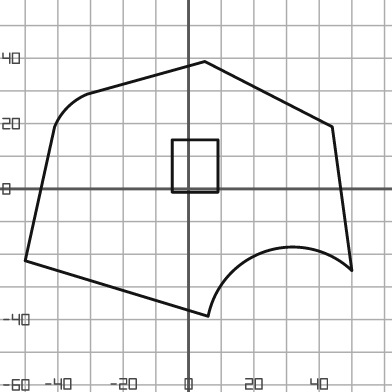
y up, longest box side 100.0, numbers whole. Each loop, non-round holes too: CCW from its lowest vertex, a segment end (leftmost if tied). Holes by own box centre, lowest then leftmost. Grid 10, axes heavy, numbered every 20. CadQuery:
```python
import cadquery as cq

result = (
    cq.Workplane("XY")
    .moveTo(6.0, -39.0)
    .threePointArc((24.0, -19.0), (50.0, -25.0))
    .lineTo(44.0, 19.0)
    .lineTo(5.0, 39.0)
    .lineTo(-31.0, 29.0)
    .threePointArc((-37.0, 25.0), (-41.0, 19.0))
    .lineTo(-50.0, -22.0)
    .close()
    .moveTo(-5.0, -1.0)
    .lineTo(9.0, -1.0)
    .lineTo(9.0, 15.0)
    .lineTo(-5.0, 15.0)
    .close()
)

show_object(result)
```